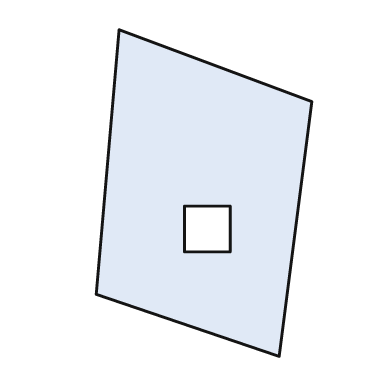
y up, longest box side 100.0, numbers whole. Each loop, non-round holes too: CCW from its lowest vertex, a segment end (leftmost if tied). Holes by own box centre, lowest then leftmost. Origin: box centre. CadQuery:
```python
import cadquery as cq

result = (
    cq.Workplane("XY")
    .moveTo(23.0, -50.0)
    .lineTo(33.0, 28.0)
    .lineTo(-26.0, 50.0)
    .lineTo(-33.0, -31.0)
    .close()
    .moveTo(-6.0, -18.0)
    .lineTo(8.0, -18.0)
    .lineTo(8.0, -4.0)
    .lineTo(-6.0, -4.0)
    .close()
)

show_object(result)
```